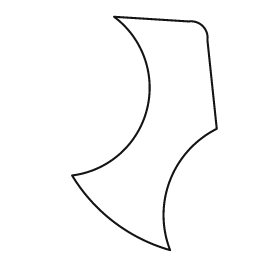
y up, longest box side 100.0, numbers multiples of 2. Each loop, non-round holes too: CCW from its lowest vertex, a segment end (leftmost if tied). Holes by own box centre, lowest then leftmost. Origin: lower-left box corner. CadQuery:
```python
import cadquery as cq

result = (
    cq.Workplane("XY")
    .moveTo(42.0, 0.0)
    .threePointArc((42.0, 30.0), (62.0, 52.0))
    .lineTo(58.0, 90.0)
    .threePointArc((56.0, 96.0), (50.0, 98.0))
    .lineTo(18.0, 100.0)
    .threePointArc((32.0, 60.0), (0.0, 32.0))
    .threePointArc((18.0, 12.0), (42.0, 0.0))
    .close()
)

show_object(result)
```